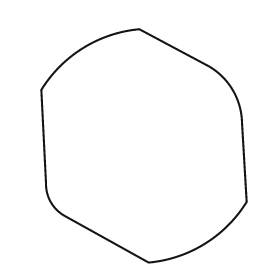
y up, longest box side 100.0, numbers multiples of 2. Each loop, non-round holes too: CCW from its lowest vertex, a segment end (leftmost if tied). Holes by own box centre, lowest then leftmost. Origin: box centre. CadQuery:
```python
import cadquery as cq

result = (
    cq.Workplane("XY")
    .moveTo(2.0, -50.0)
    .threePointArc((26.0, -42.0), (44.0, -24.0))
    .lineTo(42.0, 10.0)
    .threePointArc((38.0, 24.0), (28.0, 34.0))
    .lineTo(-2.0, 50.0)
    .threePointArc((-26.0, 42.0), (-44.0, 24.0))
    .lineTo(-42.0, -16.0)
    .threePointArc((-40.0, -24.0), (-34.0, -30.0))
    .close()
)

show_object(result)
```